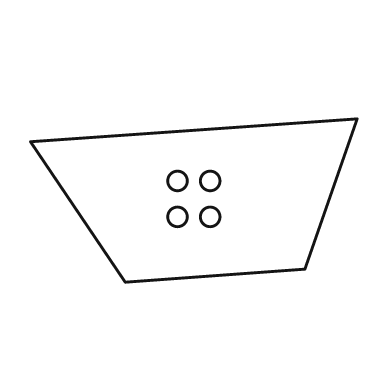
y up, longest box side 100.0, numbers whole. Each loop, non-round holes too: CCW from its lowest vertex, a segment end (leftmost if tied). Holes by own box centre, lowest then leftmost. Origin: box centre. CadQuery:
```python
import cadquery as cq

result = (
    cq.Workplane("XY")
    .moveTo(-21.0, -25.0)
    .lineTo(34.0, -21.0)
    .lineTo(50.0, 25.0)
    .lineTo(-50.0, 18.0)
    .close()
    .moveTo(-5.0, -5.0)
    .circle(3.0)
    .moveTo(5.0, -5.0)
    .circle(3.0)
    .moveTo(-5.0, 6.0)
    .circle(3.0)
    .moveTo(5.0, 6.0)
    .circle(3.0)
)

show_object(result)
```